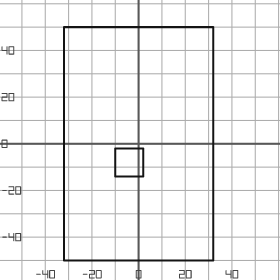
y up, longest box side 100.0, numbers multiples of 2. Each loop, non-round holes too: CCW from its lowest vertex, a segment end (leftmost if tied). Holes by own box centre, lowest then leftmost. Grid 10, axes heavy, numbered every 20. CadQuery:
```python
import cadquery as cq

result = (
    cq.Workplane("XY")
    .moveTo(-32.0, -50.0)
    .lineTo(32.0, -50.0)
    .lineTo(32.0, 50.0)
    .lineTo(-32.0, 50.0)
    .close()
    .moveTo(-10.0, -14.0)
    .lineTo(2.0, -14.0)
    .lineTo(2.0, -2.0)
    .lineTo(-10.0, -2.0)
    .close()
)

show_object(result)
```